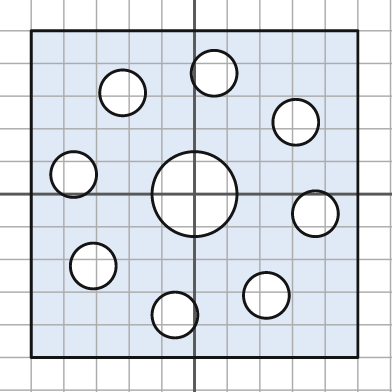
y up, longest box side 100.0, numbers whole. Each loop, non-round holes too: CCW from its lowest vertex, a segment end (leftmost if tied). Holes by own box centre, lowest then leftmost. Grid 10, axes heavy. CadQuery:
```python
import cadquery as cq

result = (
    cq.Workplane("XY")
    .moveTo(-50.0, -50.0)
    .lineTo(50.0, -50.0)
    .lineTo(50.0, 50.0)
    .lineTo(-50.0, 50.0)
    .close()
    .moveTo(-6.0, -37.0)
    .circle(7.0)
    .moveTo(22.0, -31.0)
    .circle(7.0)
    .moveTo(-31.0, -22.0)
    .circle(7.0)
    .moveTo(37.0, -6.0)
    .circle(7.0)
    .moveTo(0.0, 0.0)
    .circle(13.0)
    .moveTo(-37.0, 6.0)
    .circle(7.0)
    .moveTo(31.0, 22.0)
    .circle(7.0)
    .moveTo(-22.0, 31.0)
    .circle(7.0)
    .moveTo(6.0, 37.0)
    .circle(7.0)
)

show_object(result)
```